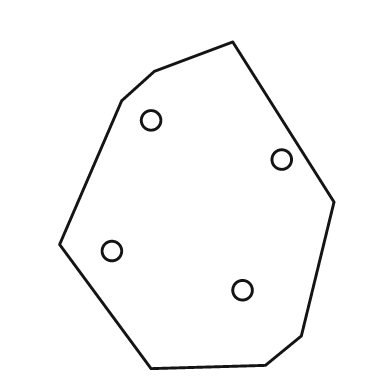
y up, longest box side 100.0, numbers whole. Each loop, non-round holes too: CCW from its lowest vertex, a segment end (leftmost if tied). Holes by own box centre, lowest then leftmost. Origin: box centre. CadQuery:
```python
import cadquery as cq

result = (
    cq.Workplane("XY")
    .moveTo(-14.0, -50.0)
    .lineTo(21.0, -49.0)
    .lineTo(32.0, -40.0)
    .lineTo(42.0, 1.0)
    .lineTo(11.0, 50.0)
    .lineTo(-13.0, 41.0)
    .lineTo(-23.0, 32.0)
    .lineTo(-42.0, -12.0)
    .close()
    .moveTo(14.0, -26.0)
    .circle(3.0)
    .moveTo(-26.0, -14.0)
    .circle(3.0)
    .moveTo(26.0, 14.0)
    .circle(3.0)
    .moveTo(-14.0, 26.0)
    .circle(3.0)
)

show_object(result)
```